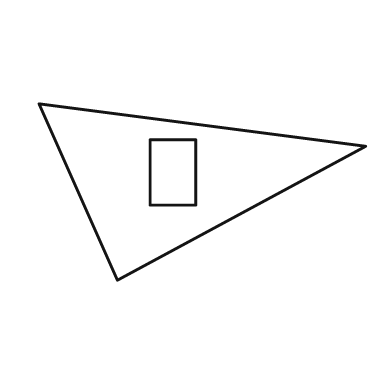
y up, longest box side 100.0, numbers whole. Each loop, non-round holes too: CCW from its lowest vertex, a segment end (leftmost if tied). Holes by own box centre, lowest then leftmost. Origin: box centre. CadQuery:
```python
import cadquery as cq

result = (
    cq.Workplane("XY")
    .moveTo(-26.0, -27.0)
    .lineTo(50.0, 14.0)
    .lineTo(-50.0, 27.0)
    .close()
    .moveTo(-16.0, -4.0)
    .lineTo(-2.0, -4.0)
    .lineTo(-2.0, 16.0)
    .lineTo(-16.0, 16.0)
    .close()
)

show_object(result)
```